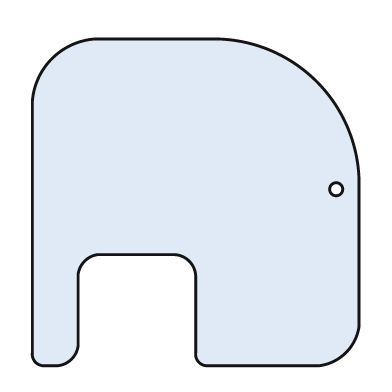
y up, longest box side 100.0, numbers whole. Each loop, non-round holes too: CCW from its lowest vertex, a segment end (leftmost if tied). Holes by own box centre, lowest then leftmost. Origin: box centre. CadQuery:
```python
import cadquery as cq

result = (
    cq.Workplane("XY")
    .moveTo(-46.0, -50.0)
    .lineTo(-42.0, -50.0)
    .threePointArc((-38.0, -48.0), (-36.0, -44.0))
    .lineTo(-36.0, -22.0)
    .threePointArc((-34.0, -18.0), (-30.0, -16.0))
    .lineTo(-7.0, -16.0)
    .threePointArc((-2.0, -18.0), (0.0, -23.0))
    .lineTo(0.0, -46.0)
    .threePointArc((1.0, -49.0), (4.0, -50.0))
    .lineTo(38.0, -50.0)
    .threePointArc((46.0, -46.0), (50.0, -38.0))
    .lineTo(50.0, 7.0)
    .threePointArc((37.0, 37.0), (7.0, 50.0))
    .lineTo(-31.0, 50.0)
    .threePointArc((-44.0, 44.0), (-50.0, 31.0))
    .lineTo(-50.0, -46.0)
    .threePointArc((-49.0, -49.0), (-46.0, -50.0))
    .close()
    .moveTo(43.0, 4.0)
    .circle(2.0)
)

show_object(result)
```